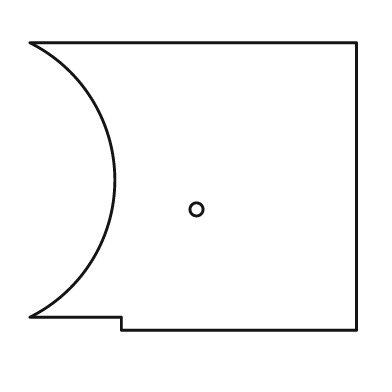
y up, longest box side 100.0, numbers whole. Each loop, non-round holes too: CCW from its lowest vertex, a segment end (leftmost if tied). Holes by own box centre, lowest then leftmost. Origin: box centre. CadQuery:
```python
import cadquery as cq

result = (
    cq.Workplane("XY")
    .moveTo(-22.0, -44.0)
    .lineTo(50.0, -44.0)
    .lineTo(50.0, 44.0)
    .lineTo(-50.0, 44.0)
    .threePointArc((-24.0, 2.0), (-50.0, -40.0))
    .lineTo(-22.0, -40.0)
    .close()
    .moveTo(1.0, -7.0)
    .circle(2.0)
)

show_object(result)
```